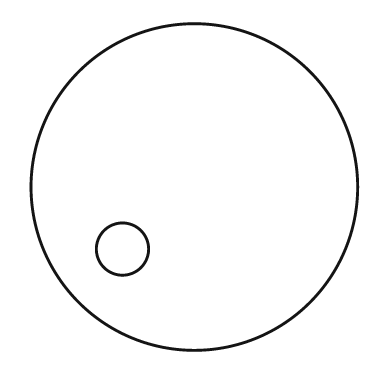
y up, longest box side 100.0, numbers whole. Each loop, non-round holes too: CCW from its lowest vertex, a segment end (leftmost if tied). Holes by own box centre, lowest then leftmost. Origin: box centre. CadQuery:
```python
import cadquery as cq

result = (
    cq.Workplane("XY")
    .moveTo(0.0, 0.0)
    .circle(50.0)
    .moveTo(-22.0, -19.0)
    .circle(8.0)
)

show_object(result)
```